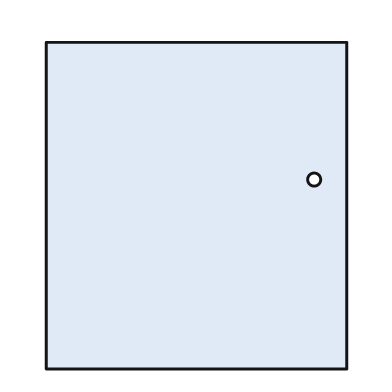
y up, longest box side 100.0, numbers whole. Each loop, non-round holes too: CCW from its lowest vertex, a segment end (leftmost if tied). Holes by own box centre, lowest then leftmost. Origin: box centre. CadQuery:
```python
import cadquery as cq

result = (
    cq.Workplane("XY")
    .moveTo(-46.0, -50.0)
    .lineTo(46.0, -50.0)
    .lineTo(46.0, 50.0)
    .lineTo(-46.0, 50.0)
    .close()
    .moveTo(36.0, 8.0)
    .circle(2.0)
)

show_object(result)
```